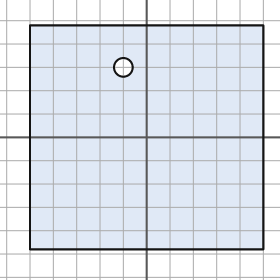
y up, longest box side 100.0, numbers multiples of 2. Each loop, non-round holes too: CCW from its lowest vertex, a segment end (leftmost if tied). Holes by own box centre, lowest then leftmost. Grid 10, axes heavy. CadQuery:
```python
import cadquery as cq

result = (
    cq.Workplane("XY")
    .moveTo(-50.0, -48.0)
    .lineTo(50.0, -48.0)
    .lineTo(50.0, 48.0)
    .lineTo(-50.0, 48.0)
    .close()
    .moveTo(-10.0, 30.0)
    .circle(4.0)
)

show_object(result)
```